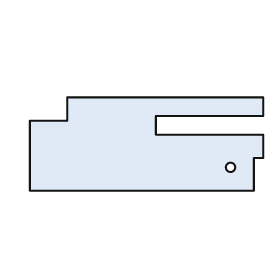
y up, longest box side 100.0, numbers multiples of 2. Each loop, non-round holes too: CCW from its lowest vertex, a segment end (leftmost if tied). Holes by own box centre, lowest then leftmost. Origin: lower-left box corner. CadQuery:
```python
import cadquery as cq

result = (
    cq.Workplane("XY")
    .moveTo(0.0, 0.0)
    .lineTo(96.0, 0.0)
    .lineTo(96.0, 14.0)
    .lineTo(100.0, 14.0)
    .lineTo(100.0, 24.0)
    .lineTo(54.0, 24.0)
    .lineTo(54.0, 32.0)
    .lineTo(100.0, 32.0)
    .lineTo(100.0, 40.0)
    .lineTo(16.0, 40.0)
    .lineTo(16.0, 30.0)
    .lineTo(0.0, 30.0)
    .close()
    .moveTo(86.0, 10.0)
    .circle(2.0)
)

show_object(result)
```